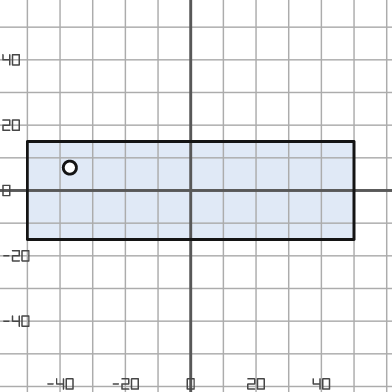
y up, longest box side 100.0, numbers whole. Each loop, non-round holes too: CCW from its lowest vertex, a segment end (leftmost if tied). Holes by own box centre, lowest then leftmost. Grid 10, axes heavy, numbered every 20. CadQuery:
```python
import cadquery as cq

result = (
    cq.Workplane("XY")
    .moveTo(-50.0, -15.0)
    .lineTo(50.0, -15.0)
    .lineTo(50.0, 15.0)
    .lineTo(-50.0, 15.0)
    .close()
    .moveTo(-37.0, 7.0)
    .circle(2.0)
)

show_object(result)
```